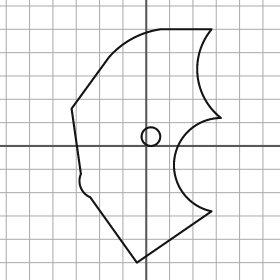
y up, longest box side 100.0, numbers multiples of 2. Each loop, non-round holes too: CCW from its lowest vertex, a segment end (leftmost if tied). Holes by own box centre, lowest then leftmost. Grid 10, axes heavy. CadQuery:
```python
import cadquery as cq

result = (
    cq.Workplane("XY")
    .moveTo(-4.0, -50.0)
    .lineTo(28.0, -28.0)
    .threePointArc((12.0, -6.0), (32.0, 12.0))
    .threePointArc((22.0, 30.0), (28.0, 50.0))
    .lineTo(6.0, 50.0)
    .threePointArc((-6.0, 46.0), (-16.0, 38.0))
    .lineTo(-32.0, 16.0)
    .lineTo(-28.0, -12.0)
    .threePointArc((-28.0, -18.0), (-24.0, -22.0))
    .close()
    .moveTo(2.0, 4.0)
    .circle(4.0)
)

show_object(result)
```